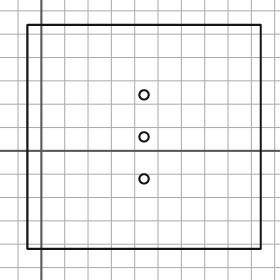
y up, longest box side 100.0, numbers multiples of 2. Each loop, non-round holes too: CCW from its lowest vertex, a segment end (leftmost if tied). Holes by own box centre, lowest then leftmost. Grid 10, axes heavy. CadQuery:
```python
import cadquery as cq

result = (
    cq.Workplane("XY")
    .moveTo(-6.0, -42.0)
    .lineTo(94.0, -42.0)
    .lineTo(94.0, 54.0)
    .lineTo(-6.0, 54.0)
    .close()
    .moveTo(44.0, -12.0)
    .circle(2.0)
    .moveTo(44.0, 6.0)
    .circle(2.0)
    .moveTo(44.0, 24.0)
    .circle(2.0)
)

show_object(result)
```